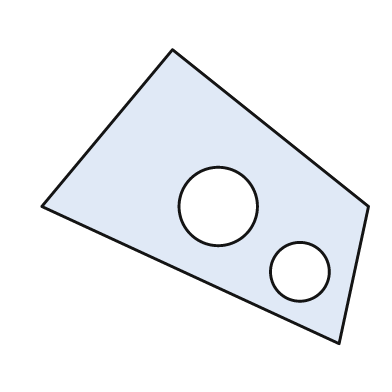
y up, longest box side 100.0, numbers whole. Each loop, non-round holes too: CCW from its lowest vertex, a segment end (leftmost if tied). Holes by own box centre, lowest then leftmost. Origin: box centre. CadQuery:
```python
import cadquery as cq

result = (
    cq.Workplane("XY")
    .moveTo(41.0, -45.0)
    .lineTo(50.0, -3.0)
    .lineTo(-10.0, 45.0)
    .lineTo(-50.0, -3.0)
    .close()
    .moveTo(29.0, -23.0)
    .circle(9.0)
    .moveTo(4.0, -3.0)
    .circle(12.0)
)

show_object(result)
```